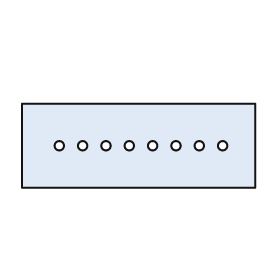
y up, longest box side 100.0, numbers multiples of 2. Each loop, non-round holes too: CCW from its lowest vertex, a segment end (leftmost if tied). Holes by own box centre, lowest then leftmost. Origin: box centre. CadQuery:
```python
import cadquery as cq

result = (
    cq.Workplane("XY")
    .moveTo(-50.0, -18.0)
    .lineTo(50.0, -18.0)
    .lineTo(50.0, 18.0)
    .lineTo(-50.0, 18.0)
    .close()
    .moveTo(-34.0, 0.0)
    .circle(2.0)
    .moveTo(-24.0, 0.0)
    .circle(2.0)
    .moveTo(-14.0, 0.0)
    .circle(2.0)
    .moveTo(-4.0, 0.0)
    .circle(2.0)
    .moveTo(6.0, 0.0)
    .circle(2.0)
    .moveTo(16.0, 0.0)
    .circle(2.0)
    .moveTo(26.0, 0.0)
    .circle(2.0)
    .moveTo(36.0, 0.0)
    .circle(2.0)
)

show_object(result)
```